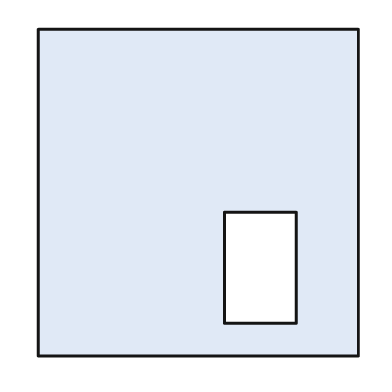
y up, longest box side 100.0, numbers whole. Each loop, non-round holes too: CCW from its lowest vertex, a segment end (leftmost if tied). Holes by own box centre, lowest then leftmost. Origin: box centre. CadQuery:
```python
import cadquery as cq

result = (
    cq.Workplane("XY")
    .moveTo(-49.0, -50.0)
    .lineTo(49.0, -50.0)
    .lineTo(49.0, 50.0)
    .lineTo(-49.0, 50.0)
    .close()
    .moveTo(8.0, -40.0)
    .lineTo(30.0, -40.0)
    .lineTo(30.0, -6.0)
    .lineTo(8.0, -6.0)
    .close()
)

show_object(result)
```